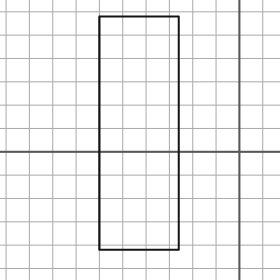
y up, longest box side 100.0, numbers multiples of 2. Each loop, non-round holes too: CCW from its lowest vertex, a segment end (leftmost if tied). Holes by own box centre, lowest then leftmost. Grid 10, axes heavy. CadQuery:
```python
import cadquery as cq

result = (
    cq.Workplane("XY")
    .moveTo(-60.0, -42.0)
    .lineTo(-26.0, -42.0)
    .lineTo(-26.0, 58.0)
    .lineTo(-60.0, 58.0)
    .close()
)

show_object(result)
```